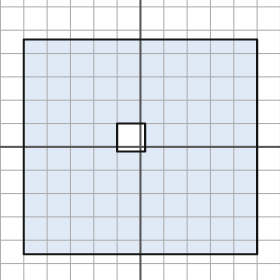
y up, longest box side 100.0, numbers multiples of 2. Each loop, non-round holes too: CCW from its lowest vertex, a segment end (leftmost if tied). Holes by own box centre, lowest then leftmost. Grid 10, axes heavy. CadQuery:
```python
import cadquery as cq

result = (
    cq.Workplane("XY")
    .moveTo(-50.0, -46.0)
    .lineTo(50.0, -46.0)
    .lineTo(50.0, 46.0)
    .lineTo(-50.0, 46.0)
    .close()
    .moveTo(-10.0, -2.0)
    .lineTo(2.0, -2.0)
    .lineTo(2.0, 10.0)
    .lineTo(-10.0, 10.0)
    .close()
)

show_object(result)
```